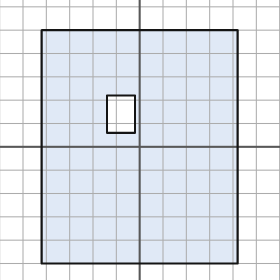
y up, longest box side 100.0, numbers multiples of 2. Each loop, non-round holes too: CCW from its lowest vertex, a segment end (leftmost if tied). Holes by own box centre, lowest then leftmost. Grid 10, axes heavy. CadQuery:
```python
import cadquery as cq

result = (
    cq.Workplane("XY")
    .moveTo(-42.0, -50.0)
    .lineTo(42.0, -50.0)
    .lineTo(42.0, 50.0)
    .lineTo(-42.0, 50.0)
    .close()
    .moveTo(-14.0, 6.0)
    .lineTo(-2.0, 6.0)
    .lineTo(-2.0, 22.0)
    .lineTo(-14.0, 22.0)
    .close()
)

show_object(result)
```